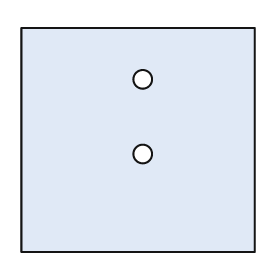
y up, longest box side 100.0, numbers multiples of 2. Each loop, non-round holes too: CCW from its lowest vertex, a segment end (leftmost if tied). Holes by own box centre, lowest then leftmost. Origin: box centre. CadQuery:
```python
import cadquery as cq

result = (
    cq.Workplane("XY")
    .moveTo(-50.0, -48.0)
    .lineTo(50.0, -48.0)
    .lineTo(50.0, 48.0)
    .lineTo(-50.0, 48.0)
    .close()
    .moveTo(2.0, -6.0)
    .circle(4.0)
    .moveTo(2.0, 26.0)
    .circle(4.0)
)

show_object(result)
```